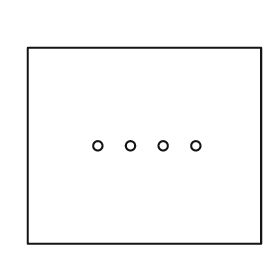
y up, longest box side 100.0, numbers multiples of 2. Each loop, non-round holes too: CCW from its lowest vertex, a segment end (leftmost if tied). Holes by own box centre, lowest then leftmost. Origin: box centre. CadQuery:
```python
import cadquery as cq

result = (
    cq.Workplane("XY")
    .moveTo(-50.0, -42.0)
    .lineTo(50.0, -42.0)
    .lineTo(50.0, 42.0)
    .lineTo(-50.0, 42.0)
    .close()
    .moveTo(-20.0, 0.0)
    .circle(2.0)
    .moveTo(-6.0, 0.0)
    .circle(2.0)
    .moveTo(8.0, 0.0)
    .circle(2.0)
    .moveTo(22.0, 0.0)
    .circle(2.0)
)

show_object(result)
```